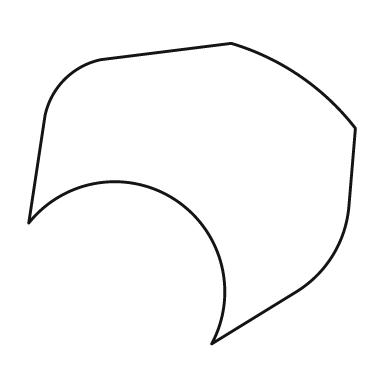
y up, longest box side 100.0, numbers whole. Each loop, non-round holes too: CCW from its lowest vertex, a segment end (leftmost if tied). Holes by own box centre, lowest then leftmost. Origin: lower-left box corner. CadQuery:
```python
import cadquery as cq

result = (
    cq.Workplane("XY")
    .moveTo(56.0, 0.0)
    .lineTo(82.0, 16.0)
    .threePointArc((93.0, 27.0), (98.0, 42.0))
    .lineTo(100.0, 66.0)
    .threePointArc((83.0, 82.0), (62.0, 92.0))
    .lineTo(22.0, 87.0)
    .threePointArc((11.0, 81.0), (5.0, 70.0))
    .lineTo(0.0, 37.0)
    .threePointArc((45.0, 44.0), (56.0, 0.0))
    .close()
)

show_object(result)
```